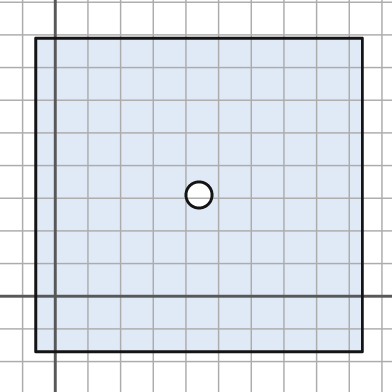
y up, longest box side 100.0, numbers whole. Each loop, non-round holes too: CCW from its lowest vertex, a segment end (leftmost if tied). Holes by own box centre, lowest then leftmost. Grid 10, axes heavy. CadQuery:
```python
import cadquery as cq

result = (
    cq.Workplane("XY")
    .moveTo(-6.0, -17.0)
    .lineTo(94.0, -17.0)
    .lineTo(94.0, 79.0)
    .lineTo(-6.0, 79.0)
    .close()
    .moveTo(44.0, 31.0)
    .circle(4.0)
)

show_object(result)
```